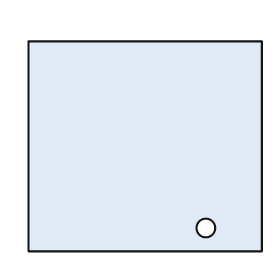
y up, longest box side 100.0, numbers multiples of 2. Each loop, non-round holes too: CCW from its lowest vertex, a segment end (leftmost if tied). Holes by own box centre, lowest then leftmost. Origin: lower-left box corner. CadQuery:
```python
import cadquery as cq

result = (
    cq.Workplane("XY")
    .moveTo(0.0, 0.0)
    .lineTo(100.0, 0.0)
    .lineTo(100.0, 90.0)
    .lineTo(0.0, 90.0)
    .close()
    .moveTo(76.0, 10.0)
    .circle(4.0)
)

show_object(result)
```